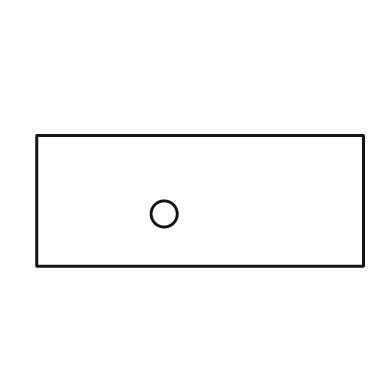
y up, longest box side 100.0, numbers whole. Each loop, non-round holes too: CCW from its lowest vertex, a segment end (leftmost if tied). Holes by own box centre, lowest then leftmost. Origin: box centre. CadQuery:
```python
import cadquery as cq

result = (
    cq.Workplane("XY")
    .moveTo(-50.0, -20.0)
    .lineTo(50.0, -20.0)
    .lineTo(50.0, 20.0)
    .lineTo(-50.0, 20.0)
    .close()
    .moveTo(-11.0, -4.0)
    .circle(4.0)
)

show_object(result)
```